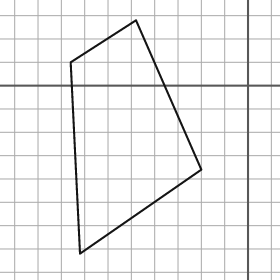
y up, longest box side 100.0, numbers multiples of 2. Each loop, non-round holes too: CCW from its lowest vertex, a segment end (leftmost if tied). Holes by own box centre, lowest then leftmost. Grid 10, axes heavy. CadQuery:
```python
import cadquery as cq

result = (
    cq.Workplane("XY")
    .moveTo(-72.0, -72.0)
    .lineTo(-20.0, -36.0)
    .lineTo(-48.0, 28.0)
    .lineTo(-76.0, 10.0)
    .close()
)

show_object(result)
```